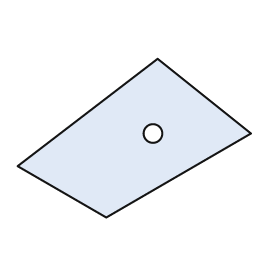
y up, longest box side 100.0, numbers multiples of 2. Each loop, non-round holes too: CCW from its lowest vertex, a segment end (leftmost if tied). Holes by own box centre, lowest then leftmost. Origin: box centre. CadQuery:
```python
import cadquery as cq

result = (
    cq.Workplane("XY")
    .moveTo(-12.0, -34.0)
    .lineTo(50.0, 2.0)
    .lineTo(10.0, 34.0)
    .lineTo(-50.0, -12.0)
    .close()
    .moveTo(8.0, 2.0)
    .circle(4.0)
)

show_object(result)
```